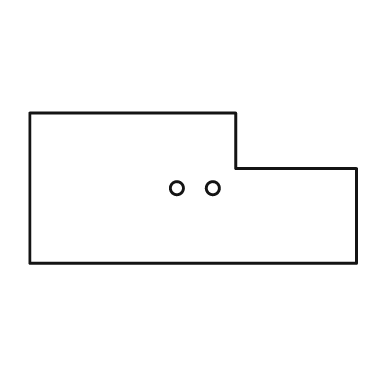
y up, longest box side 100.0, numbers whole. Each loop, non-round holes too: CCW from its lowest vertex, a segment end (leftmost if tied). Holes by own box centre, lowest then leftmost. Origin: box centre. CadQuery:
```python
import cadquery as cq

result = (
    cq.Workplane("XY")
    .moveTo(-50.0, -23.0)
    .lineTo(50.0, -23.0)
    .lineTo(50.0, 6.0)
    .lineTo(13.0, 6.0)
    .lineTo(13.0, 23.0)
    .lineTo(-50.0, 23.0)
    .close()
    .moveTo(-5.0, 0.0)
    .circle(2.0)
    .moveTo(6.0, 0.0)
    .circle(2.0)
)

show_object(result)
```